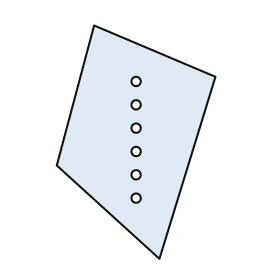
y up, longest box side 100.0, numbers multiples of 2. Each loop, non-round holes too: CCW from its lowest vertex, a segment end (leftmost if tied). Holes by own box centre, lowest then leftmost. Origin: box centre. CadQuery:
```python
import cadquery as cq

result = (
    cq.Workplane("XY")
    .moveTo(10.0, -50.0)
    .lineTo(34.0, 28.0)
    .lineTo(-18.0, 50.0)
    .lineTo(-34.0, -10.0)
    .close()
    .moveTo(0.0, -24.0)
    .circle(2.0)
    .moveTo(0.0, -14.0)
    .circle(2.0)
    .moveTo(0.0, -4.0)
    .circle(2.0)
    .moveTo(0.0, 6.0)
    .circle(2.0)
    .moveTo(0.0, 16.0)
    .circle(2.0)
    .moveTo(0.0, 26.0)
    .circle(2.0)
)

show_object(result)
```